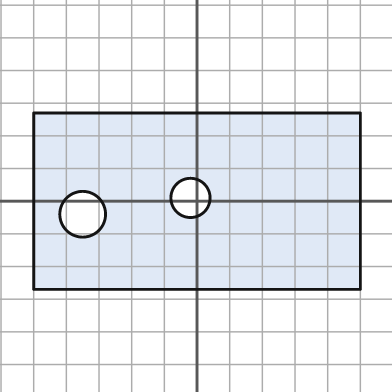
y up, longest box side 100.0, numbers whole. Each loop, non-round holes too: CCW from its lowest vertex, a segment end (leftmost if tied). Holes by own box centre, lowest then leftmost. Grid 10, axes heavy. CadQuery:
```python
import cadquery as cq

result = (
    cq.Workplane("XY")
    .moveTo(-50.0, -27.0)
    .lineTo(50.0, -27.0)
    .lineTo(50.0, 27.0)
    .lineTo(-50.0, 27.0)
    .close()
    .moveTo(-35.0, -4.0)
    .circle(7.0)
    .moveTo(-2.0, 1.0)
    .circle(6.0)
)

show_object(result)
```